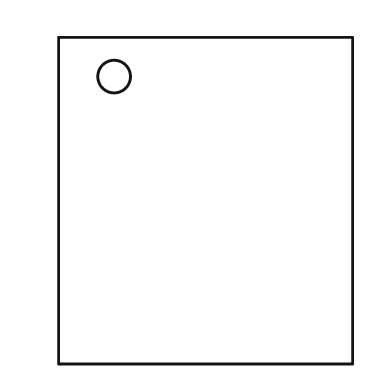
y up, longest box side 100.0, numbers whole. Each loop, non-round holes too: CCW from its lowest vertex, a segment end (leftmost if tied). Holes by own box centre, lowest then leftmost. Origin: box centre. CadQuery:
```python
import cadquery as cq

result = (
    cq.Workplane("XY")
    .moveTo(-45.0, -50.0)
    .lineTo(45.0, -50.0)
    .lineTo(45.0, 50.0)
    .lineTo(-45.0, 50.0)
    .close()
    .moveTo(-28.0, 38.0)
    .circle(5.0)
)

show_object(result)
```